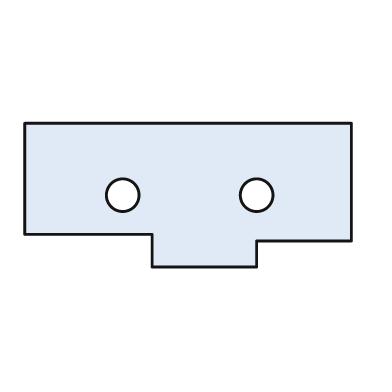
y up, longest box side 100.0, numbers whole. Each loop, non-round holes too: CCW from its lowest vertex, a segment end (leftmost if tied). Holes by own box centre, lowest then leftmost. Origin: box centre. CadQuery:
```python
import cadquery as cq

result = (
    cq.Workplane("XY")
    .moveTo(-11.0, -22.0)
    .lineTo(21.0, -22.0)
    .lineTo(21.0, -14.0)
    .lineTo(50.0, -14.0)
    .lineTo(50.0, 22.0)
    .lineTo(-50.0, 22.0)
    .lineTo(-50.0, -12.0)
    .lineTo(-11.0, -12.0)
    .close()
    .moveTo(-20.0, 0.0)
    .circle(5.0)
    .moveTo(21.0, 0.0)
    .circle(5.0)
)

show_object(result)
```